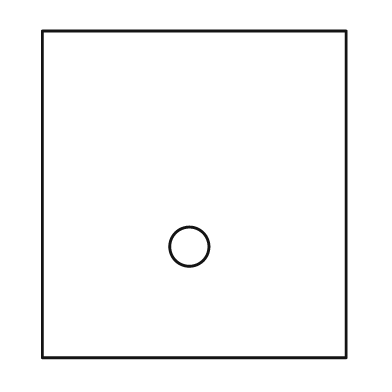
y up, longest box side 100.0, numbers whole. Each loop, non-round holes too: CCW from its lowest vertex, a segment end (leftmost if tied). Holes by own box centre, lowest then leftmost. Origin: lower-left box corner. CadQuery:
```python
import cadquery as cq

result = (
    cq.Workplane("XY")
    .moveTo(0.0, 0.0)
    .lineTo(93.0, 0.0)
    .lineTo(93.0, 100.0)
    .lineTo(0.0, 100.0)
    .close()
    .moveTo(45.0, 34.0)
    .circle(6.0)
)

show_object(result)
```